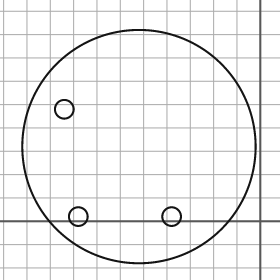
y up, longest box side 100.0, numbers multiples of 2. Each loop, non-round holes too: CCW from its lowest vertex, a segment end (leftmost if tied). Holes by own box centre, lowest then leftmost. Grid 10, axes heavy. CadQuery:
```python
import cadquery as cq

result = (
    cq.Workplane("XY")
    .moveTo(-52.0, 32.0)
    .circle(50.0)
    .moveTo(-78.0, 2.0)
    .circle(4.0)
    .moveTo(-38.0, 2.0)
    .circle(4.0)
    .moveTo(-84.0, 48.0)
    .circle(4.0)
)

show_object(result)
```